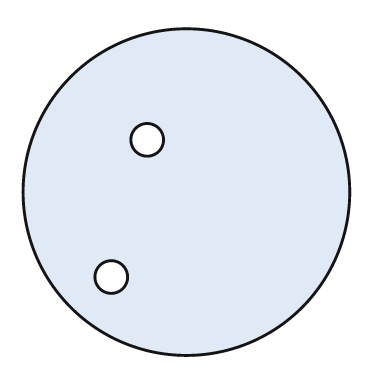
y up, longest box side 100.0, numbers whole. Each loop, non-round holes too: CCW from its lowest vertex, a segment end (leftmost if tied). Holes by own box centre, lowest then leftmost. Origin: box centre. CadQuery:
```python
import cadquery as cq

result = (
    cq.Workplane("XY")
    .moveTo(0.0, 0.0)
    .circle(50.0)
    .moveTo(-23.0, -26.0)
    .circle(5.0)
    .moveTo(-12.0, 16.0)
    .circle(5.0)
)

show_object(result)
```